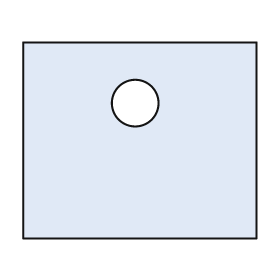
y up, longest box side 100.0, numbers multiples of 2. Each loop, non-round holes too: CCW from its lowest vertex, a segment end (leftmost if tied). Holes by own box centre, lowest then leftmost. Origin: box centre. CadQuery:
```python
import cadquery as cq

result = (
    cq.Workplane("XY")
    .moveTo(-50.0, -42.0)
    .lineTo(50.0, -42.0)
    .lineTo(50.0, 42.0)
    .lineTo(-50.0, 42.0)
    .close()
    .moveTo(-2.0, 16.0)
    .circle(10.0)
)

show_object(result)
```